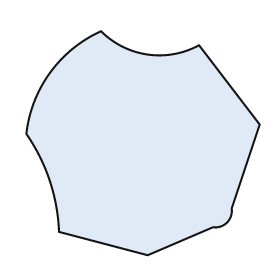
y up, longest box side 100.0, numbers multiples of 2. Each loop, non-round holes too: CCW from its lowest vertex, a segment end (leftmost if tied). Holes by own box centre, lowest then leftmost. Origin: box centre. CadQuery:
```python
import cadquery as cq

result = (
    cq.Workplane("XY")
    .moveTo(2.0, -48.0)
    .lineTo(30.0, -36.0)
    .threePointArc((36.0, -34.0), (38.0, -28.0))
    .lineTo(50.0, 8.0)
    .lineTo(24.0, 42.0)
    .threePointArc((2.0, 38.0), (-18.0, 48.0))
    .threePointArc((-40.0, 30.0), (-50.0, 4.0))
    .threePointArc((-40.0, -16.0), (-36.0, -38.0))
    .close()
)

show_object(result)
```